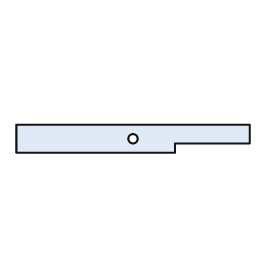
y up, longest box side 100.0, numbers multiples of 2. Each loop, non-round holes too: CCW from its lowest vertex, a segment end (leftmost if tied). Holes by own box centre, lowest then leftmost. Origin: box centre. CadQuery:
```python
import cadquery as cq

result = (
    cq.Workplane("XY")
    .moveTo(-50.0, -6.0)
    .lineTo(18.0, -6.0)
    .lineTo(18.0, -2.0)
    .lineTo(50.0, -2.0)
    .lineTo(50.0, 6.0)
    .lineTo(-50.0, 6.0)
    .close()
    .moveTo(0.0, 0.0)
    .circle(2.0)
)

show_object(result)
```